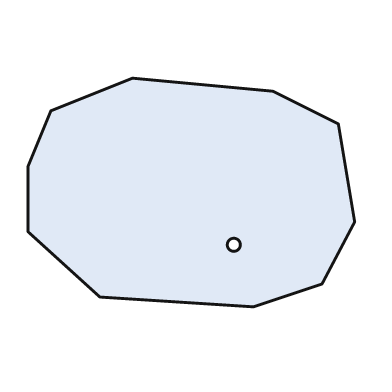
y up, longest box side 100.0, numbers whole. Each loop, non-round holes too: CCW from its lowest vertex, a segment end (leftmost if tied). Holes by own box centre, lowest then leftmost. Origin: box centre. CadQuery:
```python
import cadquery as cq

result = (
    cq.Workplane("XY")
    .moveTo(19.0, -35.0)
    .lineTo(40.0, -28.0)
    .lineTo(50.0, -9.0)
    .lineTo(45.0, 21.0)
    .lineTo(25.0, 31.0)
    .lineTo(-18.0, 35.0)
    .lineTo(-43.0, 25.0)
    .lineTo(-50.0, 8.0)
    .lineTo(-50.0, -12.0)
    .lineTo(-28.0, -32.0)
    .close()
    .moveTo(13.0, -16.0)
    .circle(2.0)
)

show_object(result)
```